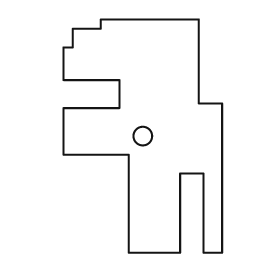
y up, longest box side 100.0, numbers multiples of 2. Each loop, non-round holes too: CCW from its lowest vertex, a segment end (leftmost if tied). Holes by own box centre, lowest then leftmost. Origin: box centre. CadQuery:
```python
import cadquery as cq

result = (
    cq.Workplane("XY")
    .moveTo(-6.0, -50.0)
    .lineTo(16.0, -50.0)
    .lineTo(16.0, -16.0)
    .lineTo(26.0, -16.0)
    .lineTo(26.0, -50.0)
    .lineTo(34.0, -50.0)
    .lineTo(34.0, 14.0)
    .lineTo(24.0, 14.0)
    .lineTo(24.0, 50.0)
    .lineTo(-18.0, 50.0)
    .lineTo(-18.0, 46.0)
    .lineTo(-30.0, 46.0)
    .lineTo(-30.0, 38.0)
    .lineTo(-34.0, 38.0)
    .lineTo(-34.0, 24.0)
    .lineTo(-10.0, 24.0)
    .lineTo(-10.0, 12.0)
    .lineTo(-34.0, 12.0)
    .lineTo(-34.0, -8.0)
    .lineTo(-6.0, -8.0)
    .close()
    .moveTo(0.0, 0.0)
    .circle(4.0)
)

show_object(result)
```